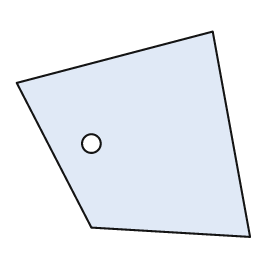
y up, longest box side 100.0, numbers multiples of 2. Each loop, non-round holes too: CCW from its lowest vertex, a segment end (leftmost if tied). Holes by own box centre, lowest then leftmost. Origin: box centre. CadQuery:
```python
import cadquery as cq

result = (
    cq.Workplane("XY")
    .moveTo(50.0, -44.0)
    .lineTo(34.0, 44.0)
    .lineTo(-50.0, 22.0)
    .lineTo(-18.0, -40.0)
    .close()
    .moveTo(-18.0, -4.0)
    .circle(4.0)
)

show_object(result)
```